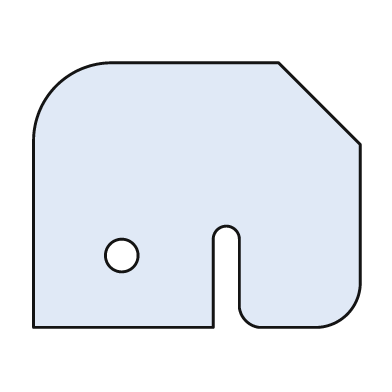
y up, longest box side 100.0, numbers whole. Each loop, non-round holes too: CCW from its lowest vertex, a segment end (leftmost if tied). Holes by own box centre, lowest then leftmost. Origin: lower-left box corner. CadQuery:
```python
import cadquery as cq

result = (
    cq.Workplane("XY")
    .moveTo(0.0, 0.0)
    .lineTo(55.0, 0.0)
    .lineTo(55.0, 27.0)
    .threePointArc((59.0, 31.0), (63.0, 27.0))
    .lineTo(63.0, 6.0)
    .threePointArc((65.0, 2.0), (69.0, 0.0))
    .lineTo(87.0, 0.0)
    .threePointArc((96.0, 4.0), (100.0, 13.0))
    .lineTo(100.0, 56.0)
    .lineTo(75.0, 81.0)
    .lineTo(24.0, 81.0)
    .threePointArc((7.0, 74.0), (0.0, 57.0))
    .close()
    .moveTo(27.0, 22.0)
    .circle(5.0)
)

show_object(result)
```